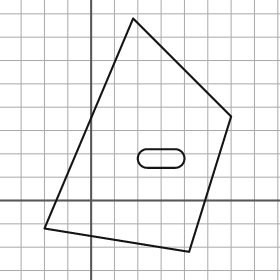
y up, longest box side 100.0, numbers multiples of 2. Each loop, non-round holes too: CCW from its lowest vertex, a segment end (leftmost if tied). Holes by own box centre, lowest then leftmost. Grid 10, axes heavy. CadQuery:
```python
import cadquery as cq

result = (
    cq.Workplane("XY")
    .moveTo(42.0, -22.0)
    .lineTo(60.0, 36.0)
    .lineTo(18.0, 78.0)
    .lineTo(-20.0, -12.0)
    .close()
    .moveTo(24.0, 14.0)
    .lineTo(36.0, 14.0)
    .threePointArc((40.0, 18.0), (36.0, 22.0))
    .lineTo(24.0, 22.0)
    .threePointArc((20.0, 18.0), (24.0, 14.0))
    .close()
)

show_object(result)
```